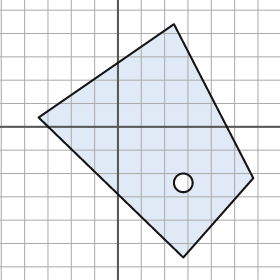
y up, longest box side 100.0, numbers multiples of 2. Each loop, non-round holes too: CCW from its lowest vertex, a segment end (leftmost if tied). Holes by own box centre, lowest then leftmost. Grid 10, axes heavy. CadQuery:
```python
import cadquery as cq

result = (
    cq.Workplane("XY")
    .moveTo(28.0, -56.0)
    .lineTo(58.0, -22.0)
    .lineTo(24.0, 44.0)
    .lineTo(-34.0, 4.0)
    .close()
    .moveTo(28.0, -24.0)
    .circle(4.0)
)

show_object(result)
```